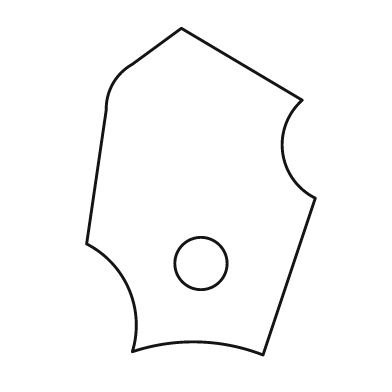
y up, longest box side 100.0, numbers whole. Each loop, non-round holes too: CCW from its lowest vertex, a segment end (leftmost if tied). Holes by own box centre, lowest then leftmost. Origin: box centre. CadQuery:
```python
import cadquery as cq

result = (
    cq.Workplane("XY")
    .moveTo(19.0, -50.0)
    .lineTo(35.0, -2.0)
    .threePointArc((25.0, 12.0), (31.0, 28.0))
    .lineTo(-6.0, 50.0)
    .lineTo(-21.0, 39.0)
    .threePointArc((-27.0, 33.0), (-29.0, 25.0))
    .lineTo(-35.0, -16.0)
    .threePointArc((-22.0, -30.0), (-21.0, -49.0))
    .threePointArc((-1.0, -46.0), (19.0, -50.0))
    .close()
    .moveTo(0.0, -22.0)
    .circle(8.0)
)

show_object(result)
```